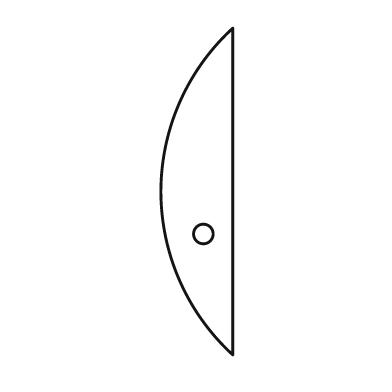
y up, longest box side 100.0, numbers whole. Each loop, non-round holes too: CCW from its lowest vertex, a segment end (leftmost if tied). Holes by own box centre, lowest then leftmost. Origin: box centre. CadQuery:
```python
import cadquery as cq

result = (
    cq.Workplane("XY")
    .moveTo(11.0, -50.0)
    .lineTo(11.0, 50.0)
    .threePointArc((-11.0, 0.0), (11.0, -50.0))
    .close()
    .moveTo(2.0, -13.0)
    .circle(3.0)
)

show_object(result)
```